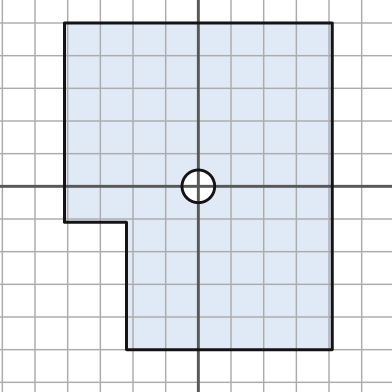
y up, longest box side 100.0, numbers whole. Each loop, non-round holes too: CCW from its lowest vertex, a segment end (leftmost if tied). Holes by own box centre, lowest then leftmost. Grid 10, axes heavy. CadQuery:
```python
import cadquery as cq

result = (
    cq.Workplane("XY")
    .moveTo(-22.0, -50.0)
    .lineTo(41.0, -50.0)
    .lineTo(41.0, 50.0)
    .lineTo(-41.0, 50.0)
    .lineTo(-41.0, -11.0)
    .lineTo(-22.0, -11.0)
    .close()
    .moveTo(0.0, 0.0)
    .circle(5.0)
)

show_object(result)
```